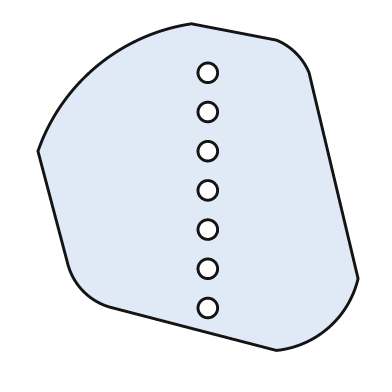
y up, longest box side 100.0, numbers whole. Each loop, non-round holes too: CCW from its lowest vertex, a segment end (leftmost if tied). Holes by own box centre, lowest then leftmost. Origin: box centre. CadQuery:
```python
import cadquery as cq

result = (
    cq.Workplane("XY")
    .moveTo(24.0, -50.0)
    .threePointArc((40.0, -43.0), (49.0, -28.0))
    .lineTo(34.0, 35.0)
    .threePointArc((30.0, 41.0), (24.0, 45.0))
    .lineTo(-2.0, 50.0)
    .threePointArc((-31.0, 37.0), (-49.0, 11.0))
    .lineTo(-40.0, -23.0)
    .threePointArc((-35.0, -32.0), (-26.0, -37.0))
    .close()
    .moveTo(3.0, -37.0)
    .circle(3.0)
    .moveTo(3.0, -25.0)
    .circle(3.0)
    .moveTo(3.0, -13.0)
    .circle(3.0)
    .moveTo(3.0, -1.0)
    .circle(3.0)
    .moveTo(3.0, 11.0)
    .circle(3.0)
    .moveTo(3.0, 23.0)
    .circle(3.0)
    .moveTo(3.0, 35.0)
    .circle(3.0)
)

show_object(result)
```